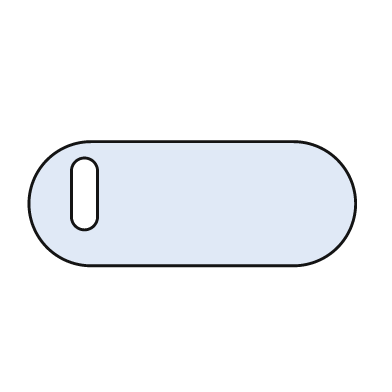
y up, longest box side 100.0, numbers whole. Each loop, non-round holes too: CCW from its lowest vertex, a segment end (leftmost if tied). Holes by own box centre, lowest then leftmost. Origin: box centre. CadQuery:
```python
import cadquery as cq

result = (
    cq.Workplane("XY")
    .moveTo(-31.0, -19.0)
    .lineTo(31.0, -19.0)
    .threePointArc((50.0, 0.0), (31.0, 19.0))
    .lineTo(-31.0, 19.0)
    .threePointArc((-50.0, 0.0), (-31.0, -19.0))
    .close()
    .moveTo(-37.0, -4.0)
    .threePointArc((-33.0, -8.0), (-29.0, -4.0))
    .lineTo(-29.0, 10.0)
    .threePointArc((-33.0, 14.0), (-37.0, 10.0))
    .close()
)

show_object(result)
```